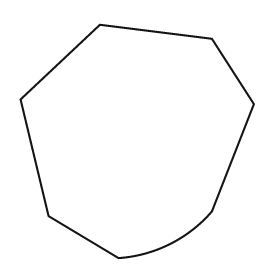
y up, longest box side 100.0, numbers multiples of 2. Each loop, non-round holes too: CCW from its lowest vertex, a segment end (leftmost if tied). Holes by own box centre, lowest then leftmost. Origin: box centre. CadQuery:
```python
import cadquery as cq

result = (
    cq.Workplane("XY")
    .moveTo(-8.0, -50.0)
    .threePointArc((14.0, -44.0), (32.0, -30.0))
    .lineTo(50.0, 16.0)
    .lineTo(32.0, 44.0)
    .lineTo(-16.0, 50.0)
    .lineTo(-50.0, 18.0)
    .lineTo(-38.0, -32.0)
    .close()
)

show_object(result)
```